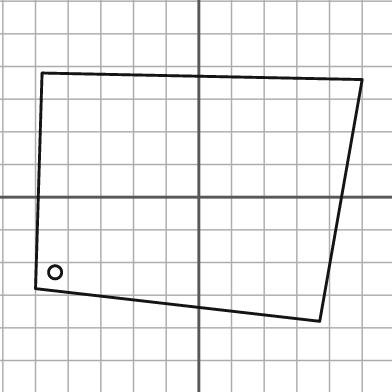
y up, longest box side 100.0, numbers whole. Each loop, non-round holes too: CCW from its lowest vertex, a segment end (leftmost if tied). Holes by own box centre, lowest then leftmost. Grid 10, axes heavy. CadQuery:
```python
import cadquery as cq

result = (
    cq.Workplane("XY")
    .moveTo(37.0, -38.0)
    .lineTo(50.0, 36.0)
    .lineTo(-48.0, 38.0)
    .lineTo(-50.0, -28.0)
    .close()
    .moveTo(-44.0, -23.0)
    .circle(2.0)
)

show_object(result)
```